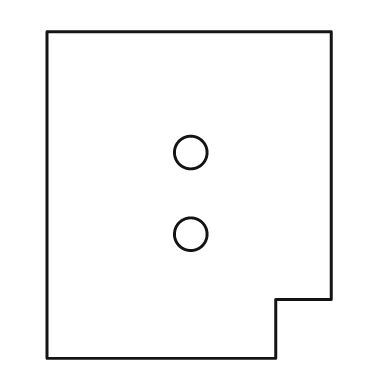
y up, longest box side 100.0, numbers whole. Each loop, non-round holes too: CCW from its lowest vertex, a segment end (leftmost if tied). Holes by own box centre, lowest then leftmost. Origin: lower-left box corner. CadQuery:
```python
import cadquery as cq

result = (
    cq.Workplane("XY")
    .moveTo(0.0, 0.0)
    .lineTo(70.0, 0.0)
    .lineTo(70.0, 18.0)
    .lineTo(87.0, 18.0)
    .lineTo(87.0, 100.0)
    .lineTo(0.0, 100.0)
    .close()
    .moveTo(44.0, 38.0)
    .circle(5.0)
    .moveTo(44.0, 63.0)
    .circle(5.0)
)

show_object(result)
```